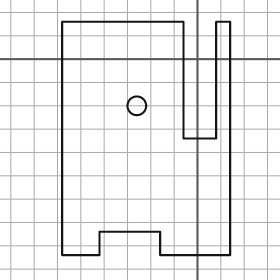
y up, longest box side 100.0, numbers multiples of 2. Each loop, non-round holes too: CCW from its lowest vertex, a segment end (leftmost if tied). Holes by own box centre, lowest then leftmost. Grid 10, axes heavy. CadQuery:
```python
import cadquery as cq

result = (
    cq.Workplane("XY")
    .moveTo(-58.0, -84.0)
    .lineTo(-42.0, -84.0)
    .lineTo(-42.0, -74.0)
    .lineTo(-16.0, -74.0)
    .lineTo(-16.0, -84.0)
    .lineTo(14.0, -84.0)
    .lineTo(14.0, 16.0)
    .lineTo(8.0, 16.0)
    .lineTo(8.0, -34.0)
    .lineTo(-6.0, -34.0)
    .lineTo(-6.0, 16.0)
    .lineTo(-58.0, 16.0)
    .close()
    .moveTo(-26.0, -20.0)
    .circle(4.0)
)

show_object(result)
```